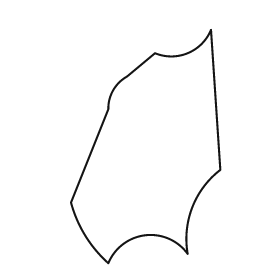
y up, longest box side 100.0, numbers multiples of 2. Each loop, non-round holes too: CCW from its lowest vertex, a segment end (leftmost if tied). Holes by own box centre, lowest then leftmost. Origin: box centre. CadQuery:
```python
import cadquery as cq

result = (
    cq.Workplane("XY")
    .moveTo(-16.0, -50.0)
    .threePointArc((0.0, -38.0), (18.0, -46.0))
    .threePointArc((20.0, -26.0), (32.0, -10.0))
    .lineTo(28.0, 50.0)
    .threePointArc((18.0, 40.0), (4.0, 40.0))
    .lineTo(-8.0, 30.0)
    .threePointArc((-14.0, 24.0), (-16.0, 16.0))
    .lineTo(-32.0, -24.0)
    .threePointArc((-26.0, -38.0), (-16.0, -50.0))
    .close()
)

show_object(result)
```